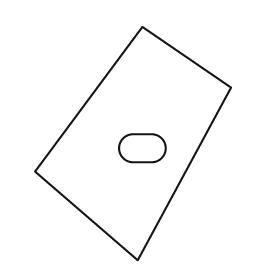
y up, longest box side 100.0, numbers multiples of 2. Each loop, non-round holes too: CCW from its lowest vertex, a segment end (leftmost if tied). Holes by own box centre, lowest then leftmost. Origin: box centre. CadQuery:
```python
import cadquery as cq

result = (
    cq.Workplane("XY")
    .moveTo(2.0, -50.0)
    .lineTo(42.0, 24.0)
    .lineTo(4.0, 50.0)
    .lineTo(-42.0, -12.0)
    .close()
    .moveTo(0.0, -8.0)
    .lineTo(8.0, -8.0)
    .threePointArc((14.0, -2.0), (8.0, 4.0))
    .lineTo(0.0, 4.0)
    .threePointArc((-6.0, -2.0), (0.0, -8.0))
    .close()
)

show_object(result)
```